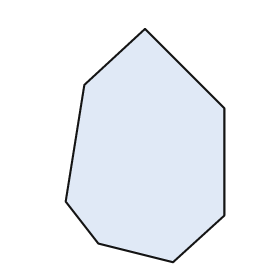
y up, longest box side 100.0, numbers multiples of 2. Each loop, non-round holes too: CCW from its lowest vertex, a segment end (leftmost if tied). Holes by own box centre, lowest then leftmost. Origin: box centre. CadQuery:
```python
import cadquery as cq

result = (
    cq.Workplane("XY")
    .moveTo(12.0, -50.0)
    .lineTo(34.0, -30.0)
    .lineTo(34.0, 16.0)
    .lineTo(0.0, 50.0)
    .lineTo(-26.0, 26.0)
    .lineTo(-34.0, -24.0)
    .lineTo(-20.0, -42.0)
    .close()
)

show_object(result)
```